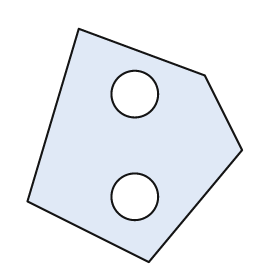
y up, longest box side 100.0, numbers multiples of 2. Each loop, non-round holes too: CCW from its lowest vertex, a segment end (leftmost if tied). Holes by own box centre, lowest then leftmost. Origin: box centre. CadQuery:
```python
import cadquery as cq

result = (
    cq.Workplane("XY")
    .moveTo(6.0, -50.0)
    .lineTo(46.0, -2.0)
    .lineTo(30.0, 30.0)
    .lineTo(-24.0, 50.0)
    .lineTo(-46.0, -24.0)
    .close()
    .moveTo(0.0, -22.0)
    .circle(10.0)
    .moveTo(0.0, 22.0)
    .circle(10.0)
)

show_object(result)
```